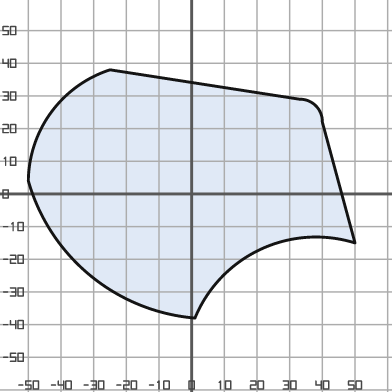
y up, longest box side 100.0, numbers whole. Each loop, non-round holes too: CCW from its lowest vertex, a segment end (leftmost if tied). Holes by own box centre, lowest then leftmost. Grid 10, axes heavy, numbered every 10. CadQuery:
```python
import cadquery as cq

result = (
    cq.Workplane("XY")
    .moveTo(1.0, -38.0)
    .threePointArc((21.0, -17.0), (50.0, -15.0))
    .lineTo(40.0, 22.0)
    .threePointArc((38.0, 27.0), (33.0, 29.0))
    .lineTo(-25.0, 38.0)
    .threePointArc((-43.0, 25.0), (-50.0, 4.0))
    .threePointArc((-31.0, -25.0), (1.0, -38.0))
    .close()
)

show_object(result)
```